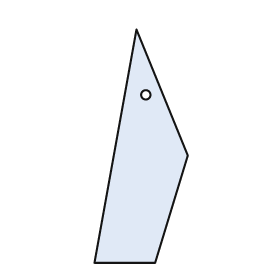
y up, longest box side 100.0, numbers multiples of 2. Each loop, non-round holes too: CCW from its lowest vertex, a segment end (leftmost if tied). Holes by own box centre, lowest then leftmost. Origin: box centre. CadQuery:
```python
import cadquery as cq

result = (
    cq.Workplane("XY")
    .moveTo(-20.0, -50.0)
    .lineTo(6.0, -50.0)
    .lineTo(20.0, -4.0)
    .lineTo(-2.0, 50.0)
    .close()
    .moveTo(2.0, 22.0)
    .circle(2.0)
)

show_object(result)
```